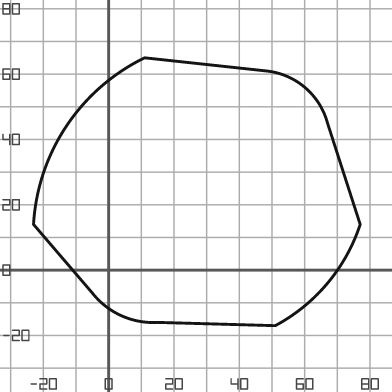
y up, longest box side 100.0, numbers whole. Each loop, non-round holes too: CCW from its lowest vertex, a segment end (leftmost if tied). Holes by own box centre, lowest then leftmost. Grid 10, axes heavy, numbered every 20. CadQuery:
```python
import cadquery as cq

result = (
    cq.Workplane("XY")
    .moveTo(51.0, -17.0)
    .threePointArc((67.0, -4.0), (77.0, 14.0))
    .lineTo(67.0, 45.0)
    .threePointArc((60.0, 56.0), (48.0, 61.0))
    .lineTo(11.0, 65.0)
    .threePointArc((-13.0, 44.0), (-23.0, 14.0))
    .lineTo(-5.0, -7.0)
    .threePointArc((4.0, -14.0), (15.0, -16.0))
    .close()
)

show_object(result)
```